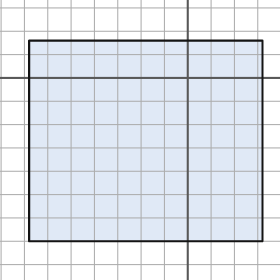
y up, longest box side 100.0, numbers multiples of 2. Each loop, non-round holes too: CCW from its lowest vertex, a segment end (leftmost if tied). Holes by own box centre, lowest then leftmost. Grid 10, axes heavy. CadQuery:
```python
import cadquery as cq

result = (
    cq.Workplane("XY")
    .moveTo(-68.0, -70.0)
    .lineTo(32.0, -70.0)
    .lineTo(32.0, 16.0)
    .lineTo(-68.0, 16.0)
    .close()
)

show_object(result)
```